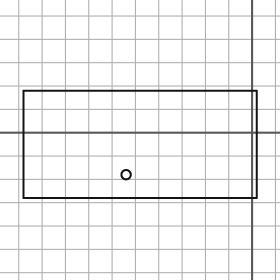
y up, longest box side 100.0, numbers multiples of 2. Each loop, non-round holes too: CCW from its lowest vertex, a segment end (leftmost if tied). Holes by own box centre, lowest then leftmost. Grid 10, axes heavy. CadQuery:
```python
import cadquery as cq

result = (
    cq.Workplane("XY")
    .moveTo(-98.0, -28.0)
    .lineTo(2.0, -28.0)
    .lineTo(2.0, 18.0)
    .lineTo(-98.0, 18.0)
    .close()
    .moveTo(-54.0, -18.0)
    .circle(2.0)
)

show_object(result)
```